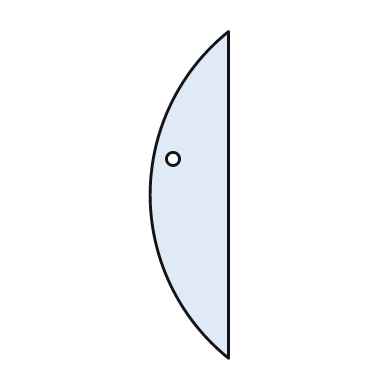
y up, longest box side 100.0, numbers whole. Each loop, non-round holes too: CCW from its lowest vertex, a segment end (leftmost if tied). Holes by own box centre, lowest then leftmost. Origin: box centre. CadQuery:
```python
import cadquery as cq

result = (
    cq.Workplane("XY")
    .moveTo(12.0, -50.0)
    .lineTo(12.0, 50.0)
    .threePointArc((-12.0, 0.0), (12.0, -50.0))
    .close()
    .moveTo(-5.0, 11.0)
    .circle(2.0)
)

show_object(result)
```